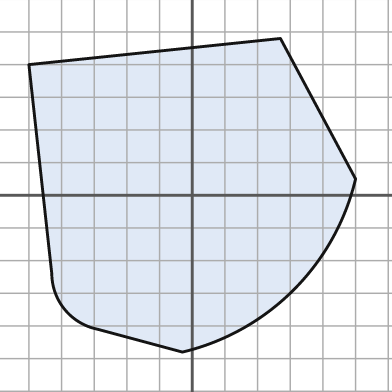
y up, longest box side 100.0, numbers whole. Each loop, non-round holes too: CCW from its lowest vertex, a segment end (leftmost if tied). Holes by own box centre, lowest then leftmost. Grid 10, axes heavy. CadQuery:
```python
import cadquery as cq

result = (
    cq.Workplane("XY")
    .moveTo(-3.0, -48.0)
    .threePointArc((31.0, -29.0), (50.0, 5.0))
    .lineTo(27.0, 48.0)
    .lineTo(-50.0, 40.0)
    .lineTo(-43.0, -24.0)
    .threePointArc((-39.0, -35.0), (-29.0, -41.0))
    .close()
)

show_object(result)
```